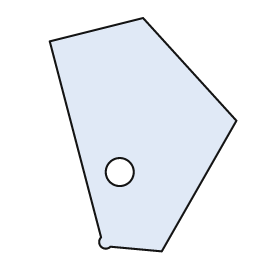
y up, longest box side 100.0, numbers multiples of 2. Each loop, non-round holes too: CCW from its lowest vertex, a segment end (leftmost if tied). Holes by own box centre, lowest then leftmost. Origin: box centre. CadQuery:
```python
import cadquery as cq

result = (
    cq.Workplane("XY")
    .moveTo(8.0, -50.0)
    .lineTo(40.0, 6.0)
    .lineTo(0.0, 50.0)
    .lineTo(-40.0, 40.0)
    .lineTo(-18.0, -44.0)
    .threePointArc((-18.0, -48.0), (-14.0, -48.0))
    .close()
    .moveTo(-10.0, -16.0)
    .circle(6.0)
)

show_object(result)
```